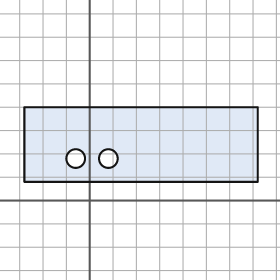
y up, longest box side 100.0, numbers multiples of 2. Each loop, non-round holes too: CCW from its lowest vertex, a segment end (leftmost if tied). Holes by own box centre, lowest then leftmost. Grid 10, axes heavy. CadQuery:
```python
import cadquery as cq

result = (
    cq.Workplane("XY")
    .moveTo(-28.0, 8.0)
    .lineTo(72.0, 8.0)
    .lineTo(72.0, 40.0)
    .lineTo(-28.0, 40.0)
    .close()
    .moveTo(-6.0, 18.0)
    .circle(4.0)
    .moveTo(8.0, 18.0)
    .circle(4.0)
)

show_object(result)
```